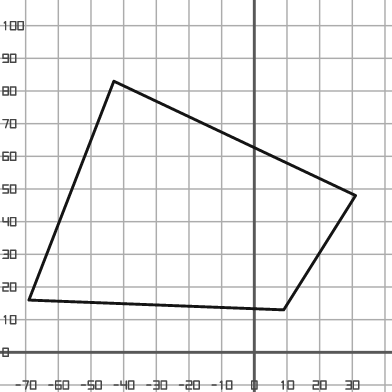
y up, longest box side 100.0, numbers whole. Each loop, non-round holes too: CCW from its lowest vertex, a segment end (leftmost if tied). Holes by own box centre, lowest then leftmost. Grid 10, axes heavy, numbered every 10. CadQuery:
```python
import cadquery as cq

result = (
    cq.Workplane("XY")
    .moveTo(9.0, 13.0)
    .lineTo(31.0, 48.0)
    .lineTo(-43.0, 83.0)
    .lineTo(-69.0, 16.0)
    .close()
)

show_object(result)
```